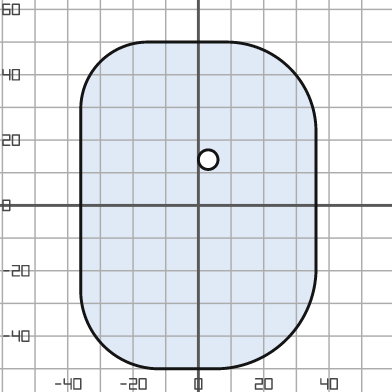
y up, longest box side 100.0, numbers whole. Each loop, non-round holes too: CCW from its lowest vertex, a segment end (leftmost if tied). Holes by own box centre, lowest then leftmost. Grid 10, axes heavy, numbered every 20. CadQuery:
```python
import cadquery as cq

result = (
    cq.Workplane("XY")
    .moveTo(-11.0, -50.0)
    .lineTo(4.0, -50.0)
    .threePointArc((27.0, -41.0), (36.0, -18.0))
    .lineTo(36.0, 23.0)
    .threePointArc((28.0, 42.0), (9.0, 50.0))
    .lineTo(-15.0, 50.0)
    .threePointArc((-30.0, 44.0), (-36.0, 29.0))
    .lineTo(-36.0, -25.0)
    .threePointArc((-29.0, -43.0), (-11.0, -50.0))
    .close()
    .moveTo(3.0, 14.0)
    .circle(3.0)
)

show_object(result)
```